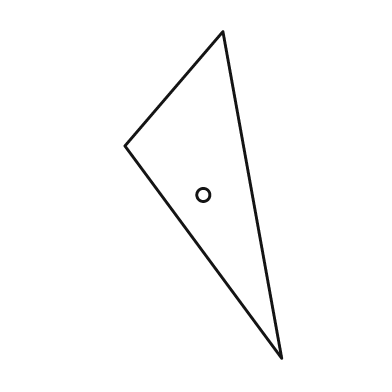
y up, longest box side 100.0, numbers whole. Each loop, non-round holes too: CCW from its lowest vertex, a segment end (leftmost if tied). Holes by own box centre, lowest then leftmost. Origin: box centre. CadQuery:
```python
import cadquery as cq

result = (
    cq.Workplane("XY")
    .moveTo(24.0, -50.0)
    .lineTo(6.0, 50.0)
    .lineTo(-24.0, 15.0)
    .close()
    .moveTo(0.0, 0.0)
    .circle(2.0)
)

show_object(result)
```